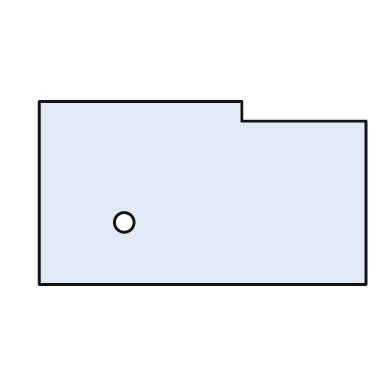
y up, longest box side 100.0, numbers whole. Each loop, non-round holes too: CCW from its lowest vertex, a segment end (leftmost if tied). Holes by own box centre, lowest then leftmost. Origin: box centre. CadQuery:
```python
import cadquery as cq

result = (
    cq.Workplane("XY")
    .moveTo(-50.0, -28.0)
    .lineTo(50.0, -28.0)
    .lineTo(50.0, 22.0)
    .lineTo(12.0, 22.0)
    .lineTo(12.0, 28.0)
    .lineTo(-50.0, 28.0)
    .close()
    .moveTo(-24.0, -9.0)
    .circle(3.0)
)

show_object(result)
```